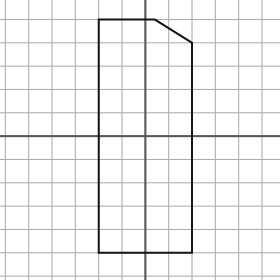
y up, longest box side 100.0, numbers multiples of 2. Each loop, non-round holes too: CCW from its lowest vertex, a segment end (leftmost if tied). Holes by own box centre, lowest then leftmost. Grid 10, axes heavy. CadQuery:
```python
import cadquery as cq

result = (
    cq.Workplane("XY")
    .moveTo(-20.0, -50.0)
    .lineTo(20.0, -50.0)
    .lineTo(20.0, 40.0)
    .lineTo(4.0, 50.0)
    .lineTo(-20.0, 50.0)
    .close()
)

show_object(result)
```